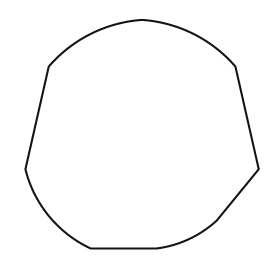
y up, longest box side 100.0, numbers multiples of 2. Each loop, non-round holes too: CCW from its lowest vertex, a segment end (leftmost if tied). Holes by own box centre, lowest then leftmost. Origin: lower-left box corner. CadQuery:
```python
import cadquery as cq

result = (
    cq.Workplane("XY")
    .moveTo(28.0, 0.0)
    .lineTo(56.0, 0.0)
    .threePointArc((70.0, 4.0), (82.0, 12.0))
    .lineTo(100.0, 34.0)
    .lineTo(90.0, 78.0)
    .threePointArc((72.0, 92.0), (50.0, 98.0))
    .threePointArc((28.0, 92.0), (10.0, 78.0))
    .lineTo(0.0, 34.0)
    .threePointArc((10.0, 14.0), (28.0, 0.0))
    .close()
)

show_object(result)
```